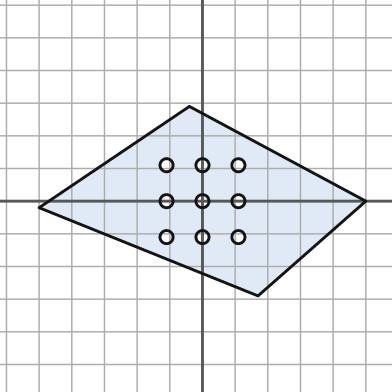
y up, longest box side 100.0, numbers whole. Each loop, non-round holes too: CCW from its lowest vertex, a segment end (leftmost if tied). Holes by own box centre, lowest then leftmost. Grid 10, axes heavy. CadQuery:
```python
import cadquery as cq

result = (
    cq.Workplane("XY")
    .moveTo(17.0, -29.0)
    .lineTo(50.0, 0.0)
    .lineTo(-4.0, 29.0)
    .lineTo(-50.0, -2.0)
    .close()
    .moveTo(-11.0, -11.0)
    .circle(2.0)
    .moveTo(0.0, -11.0)
    .circle(2.0)
    .moveTo(11.0, -11.0)
    .circle(2.0)
    .moveTo(-11.0, 0.0)
    .circle(2.0)
    .moveTo(0.0, 0.0)
    .circle(2.0)
    .moveTo(11.0, 0.0)
    .circle(2.0)
    .moveTo(-11.0, 11.0)
    .circle(2.0)
    .moveTo(0.0, 11.0)
    .circle(2.0)
    .moveTo(11.0, 11.0)
    .circle(2.0)
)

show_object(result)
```